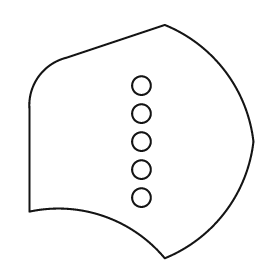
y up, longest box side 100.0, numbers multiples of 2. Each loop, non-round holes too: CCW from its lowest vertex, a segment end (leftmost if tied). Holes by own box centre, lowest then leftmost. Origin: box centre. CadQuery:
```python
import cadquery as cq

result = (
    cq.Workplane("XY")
    .moveTo(10.0, -50.0)
    .threePointArc((36.0, -30.0), (48.0, 0.0))
    .threePointArc((36.0, 30.0), (10.0, 50.0))
    .lineTo(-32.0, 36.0)
    .threePointArc((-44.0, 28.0), (-48.0, 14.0))
    .lineTo(-48.0, -30.0)
    .threePointArc((-16.0, -32.0), (10.0, -50.0))
    .close()
    .moveTo(0.0, -24.0)
    .circle(4.0)
    .moveTo(0.0, -12.0)
    .circle(4.0)
    .moveTo(0.0, 0.0)
    .circle(4.0)
    .moveTo(0.0, 12.0)
    .circle(4.0)
    .moveTo(0.0, 24.0)
    .circle(4.0)
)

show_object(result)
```